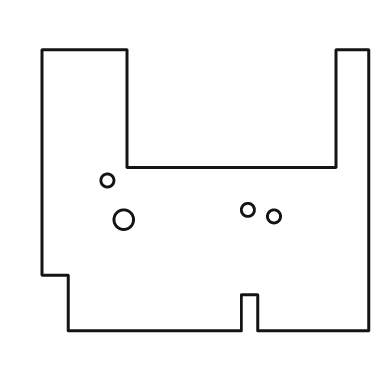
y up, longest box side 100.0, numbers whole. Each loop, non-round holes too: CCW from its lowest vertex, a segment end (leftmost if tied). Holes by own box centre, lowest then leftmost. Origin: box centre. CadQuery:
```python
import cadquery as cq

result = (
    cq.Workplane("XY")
    .moveTo(-42.0, -43.0)
    .lineTo(11.0, -43.0)
    .lineTo(11.0, -32.0)
    .lineTo(16.0, -32.0)
    .lineTo(16.0, -43.0)
    .lineTo(50.0, -43.0)
    .lineTo(50.0, 43.0)
    .lineTo(40.0, 43.0)
    .lineTo(40.0, 7.0)
    .lineTo(-24.0, 7.0)
    .lineTo(-24.0, 43.0)
    .lineTo(-50.0, 43.0)
    .lineTo(-50.0, -26.0)
    .lineTo(-42.0, -26.0)
    .close()
    .moveTo(-25.0, -9.0)
    .circle(3.0)
    .moveTo(21.0, -8.0)
    .circle(2.0)
    .moveTo(13.0, -6.0)
    .circle(2.0)
    .moveTo(-30.0, 3.0)
    .circle(2.0)
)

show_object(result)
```